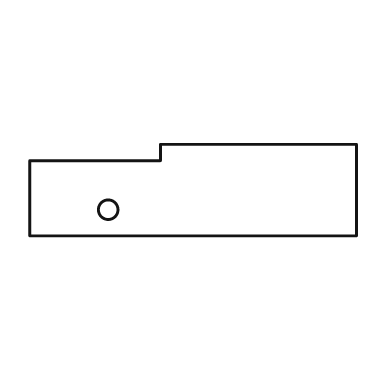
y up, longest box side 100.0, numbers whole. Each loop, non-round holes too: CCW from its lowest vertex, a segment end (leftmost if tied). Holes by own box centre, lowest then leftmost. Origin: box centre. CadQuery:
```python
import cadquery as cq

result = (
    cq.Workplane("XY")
    .moveTo(-50.0, -14.0)
    .lineTo(50.0, -14.0)
    .lineTo(50.0, 14.0)
    .lineTo(-10.0, 14.0)
    .lineTo(-10.0, 9.0)
    .lineTo(-50.0, 9.0)
    .close()
    .moveTo(-26.0, -6.0)
    .circle(3.0)
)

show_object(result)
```